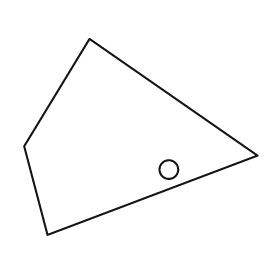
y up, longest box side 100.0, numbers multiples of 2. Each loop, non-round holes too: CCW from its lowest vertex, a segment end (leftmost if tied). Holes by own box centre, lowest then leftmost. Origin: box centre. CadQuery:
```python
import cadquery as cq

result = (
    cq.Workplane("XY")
    .moveTo(-40.0, -42.0)
    .lineTo(50.0, -8.0)
    .lineTo(-22.0, 42.0)
    .lineTo(-50.0, -4.0)
    .close()
    .moveTo(12.0, -14.0)
    .circle(4.0)
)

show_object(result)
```